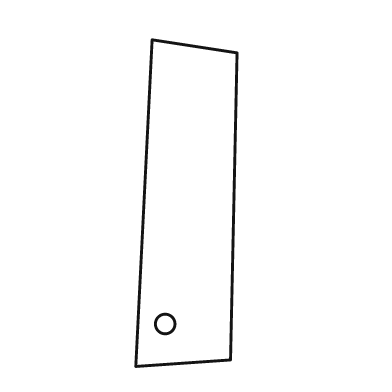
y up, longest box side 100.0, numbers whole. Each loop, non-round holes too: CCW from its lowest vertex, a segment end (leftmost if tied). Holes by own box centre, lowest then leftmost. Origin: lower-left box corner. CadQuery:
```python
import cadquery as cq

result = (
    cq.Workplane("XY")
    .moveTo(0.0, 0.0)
    .lineTo(29.0, 2.0)
    .lineTo(31.0, 96.0)
    .lineTo(5.0, 100.0)
    .close()
    .moveTo(9.0, 13.0)
    .circle(3.0)
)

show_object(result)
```